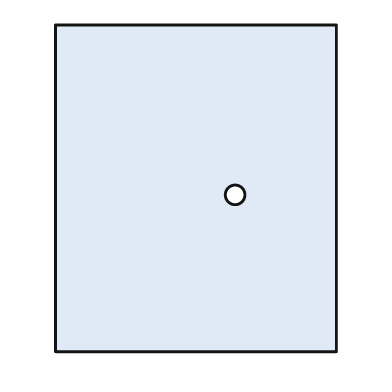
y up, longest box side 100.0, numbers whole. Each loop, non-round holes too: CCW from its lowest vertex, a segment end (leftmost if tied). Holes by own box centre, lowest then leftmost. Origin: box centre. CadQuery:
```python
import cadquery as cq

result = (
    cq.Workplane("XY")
    .moveTo(-43.0, -50.0)
    .lineTo(43.0, -50.0)
    .lineTo(43.0, 50.0)
    .lineTo(-43.0, 50.0)
    .close()
    .moveTo(12.0, -2.0)
    .circle(3.0)
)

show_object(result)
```